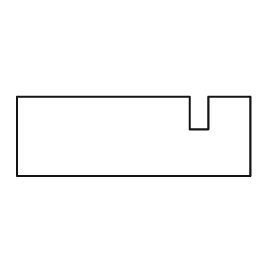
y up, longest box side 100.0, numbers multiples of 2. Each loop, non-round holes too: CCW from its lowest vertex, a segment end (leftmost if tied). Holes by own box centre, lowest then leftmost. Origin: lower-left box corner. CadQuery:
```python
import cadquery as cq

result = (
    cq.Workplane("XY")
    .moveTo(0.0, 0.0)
    .lineTo(100.0, 0.0)
    .lineTo(100.0, 34.0)
    .lineTo(82.0, 34.0)
    .lineTo(82.0, 20.0)
    .lineTo(74.0, 20.0)
    .lineTo(74.0, 34.0)
    .lineTo(0.0, 34.0)
    .close()
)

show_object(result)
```